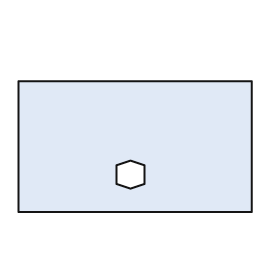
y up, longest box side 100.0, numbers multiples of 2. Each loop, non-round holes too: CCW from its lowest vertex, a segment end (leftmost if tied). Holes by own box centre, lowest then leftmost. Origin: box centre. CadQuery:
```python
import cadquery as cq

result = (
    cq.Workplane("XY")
    .moveTo(-50.0, -28.0)
    .lineTo(50.0, -28.0)
    .lineTo(50.0, 28.0)
    .lineTo(-50.0, 28.0)
    .close()
    .moveTo(-2.0, -18.0)
    .lineTo(4.0, -16.0)
    .lineTo(4.0, -8.0)
    .lineTo(-2.0, -6.0)
    .lineTo(-8.0, -8.0)
    .lineTo(-8.0, -16.0)
    .close()
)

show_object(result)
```